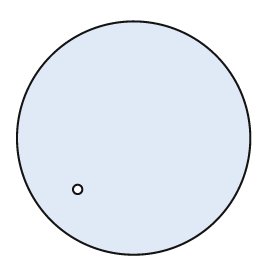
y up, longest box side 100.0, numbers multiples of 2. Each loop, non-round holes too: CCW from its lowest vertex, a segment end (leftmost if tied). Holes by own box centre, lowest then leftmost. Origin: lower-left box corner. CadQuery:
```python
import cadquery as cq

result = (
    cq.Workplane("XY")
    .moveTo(50.0, 50.0)
    .circle(50.0)
    .moveTo(26.0, 28.0)
    .circle(2.0)
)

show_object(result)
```